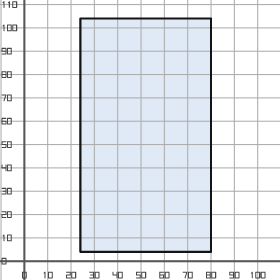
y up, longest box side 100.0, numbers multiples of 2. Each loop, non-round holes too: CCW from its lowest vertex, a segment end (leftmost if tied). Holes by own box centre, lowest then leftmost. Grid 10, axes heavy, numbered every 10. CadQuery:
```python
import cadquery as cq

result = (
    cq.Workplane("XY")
    .moveTo(24.0, 4.0)
    .lineTo(80.0, 4.0)
    .lineTo(80.0, 104.0)
    .lineTo(24.0, 104.0)
    .close()
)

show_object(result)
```